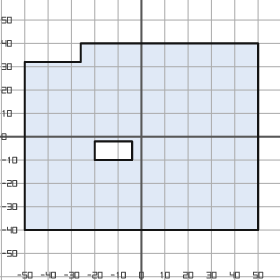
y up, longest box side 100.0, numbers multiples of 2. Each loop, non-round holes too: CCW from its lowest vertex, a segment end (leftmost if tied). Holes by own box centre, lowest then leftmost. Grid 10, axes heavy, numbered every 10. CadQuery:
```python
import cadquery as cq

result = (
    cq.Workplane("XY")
    .moveTo(-50.0, -40.0)
    .lineTo(50.0, -40.0)
    .lineTo(50.0, 40.0)
    .lineTo(-26.0, 40.0)
    .lineTo(-26.0, 32.0)
    .lineTo(-50.0, 32.0)
    .close()
    .moveTo(-20.0, -10.0)
    .lineTo(-4.0, -10.0)
    .lineTo(-4.0, -2.0)
    .lineTo(-20.0, -2.0)
    .close()
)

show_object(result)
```